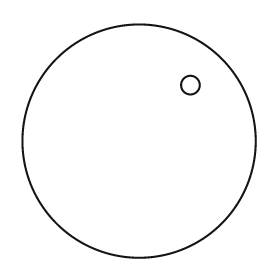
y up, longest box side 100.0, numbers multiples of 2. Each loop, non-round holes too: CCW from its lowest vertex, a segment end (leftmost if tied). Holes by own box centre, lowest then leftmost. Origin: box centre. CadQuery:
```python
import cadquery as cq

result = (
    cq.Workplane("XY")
    .moveTo(0.0, 0.0)
    .circle(50.0)
    .moveTo(22.0, 24.0)
    .circle(4.0)
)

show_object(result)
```